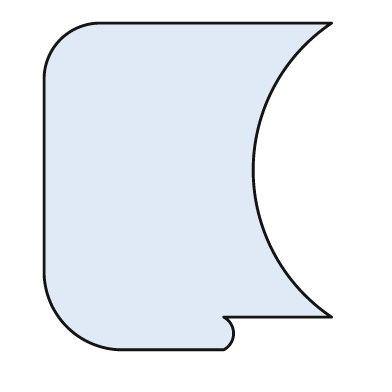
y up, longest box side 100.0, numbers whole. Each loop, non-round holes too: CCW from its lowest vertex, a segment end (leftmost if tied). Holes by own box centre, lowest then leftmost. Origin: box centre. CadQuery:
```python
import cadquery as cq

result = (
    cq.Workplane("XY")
    .moveTo(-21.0, -50.0)
    .lineTo(11.0, -50.0)
    .threePointArc((14.0, -45.0), (11.0, -40.0))
    .lineTo(44.0, -40.0)
    .threePointArc((20.0, 5.0), (44.0, 50.0))
    .lineTo(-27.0, 50.0)
    .threePointArc((-39.0, 45.0), (-44.0, 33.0))
    .lineTo(-44.0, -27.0)
    .threePointArc((-37.0, -43.0), (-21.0, -50.0))
    .close()
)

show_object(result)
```